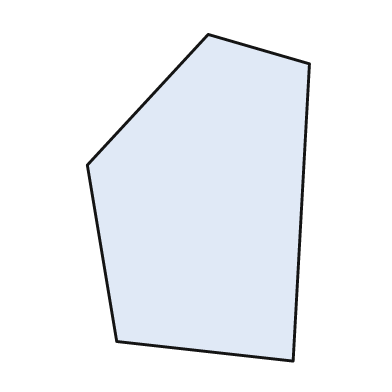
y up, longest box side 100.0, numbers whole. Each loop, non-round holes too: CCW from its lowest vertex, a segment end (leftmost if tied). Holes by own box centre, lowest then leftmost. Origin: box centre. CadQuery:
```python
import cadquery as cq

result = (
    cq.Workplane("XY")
    .moveTo(29.0, -50.0)
    .lineTo(34.0, 41.0)
    .lineTo(3.0, 50.0)
    .lineTo(-34.0, 10.0)
    .lineTo(-25.0, -44.0)
    .close()
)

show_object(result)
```